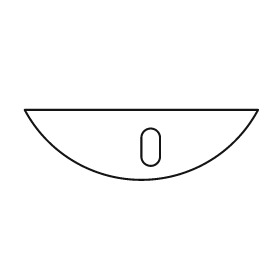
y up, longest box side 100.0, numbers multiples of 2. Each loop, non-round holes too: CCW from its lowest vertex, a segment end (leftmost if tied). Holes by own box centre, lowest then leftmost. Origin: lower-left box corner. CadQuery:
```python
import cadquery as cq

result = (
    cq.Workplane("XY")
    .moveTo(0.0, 30.0)
    .threePointArc((50.0, 0.0), (100.0, 30.0))
    .close()
    .moveTo(50.0, 10.0)
    .threePointArc((54.0, 6.0), (58.0, 10.0))
    .lineTo(58.0, 18.0)
    .threePointArc((54.0, 22.0), (50.0, 18.0))
    .close()
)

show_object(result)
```